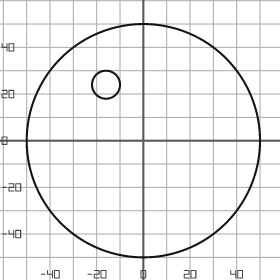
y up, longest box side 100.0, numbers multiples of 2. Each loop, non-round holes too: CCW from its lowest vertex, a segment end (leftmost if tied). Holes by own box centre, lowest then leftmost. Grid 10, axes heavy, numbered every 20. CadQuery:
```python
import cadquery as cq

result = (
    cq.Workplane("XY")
    .moveTo(0.0, 0.0)
    .circle(50.0)
    .moveTo(-16.0, 24.0)
    .circle(6.0)
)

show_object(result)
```